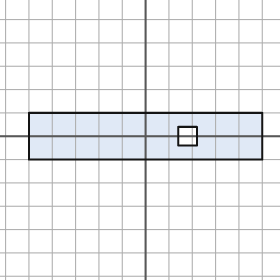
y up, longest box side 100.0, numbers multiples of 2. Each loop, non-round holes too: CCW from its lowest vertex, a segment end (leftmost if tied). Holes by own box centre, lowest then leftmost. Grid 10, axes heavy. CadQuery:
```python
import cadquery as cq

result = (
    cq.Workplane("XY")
    .moveTo(-50.0, -10.0)
    .lineTo(50.0, -10.0)
    .lineTo(50.0, 10.0)
    .lineTo(-50.0, 10.0)
    .close()
    .moveTo(14.0, -4.0)
    .lineTo(22.0, -4.0)
    .lineTo(22.0, 4.0)
    .lineTo(14.0, 4.0)
    .close()
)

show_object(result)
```